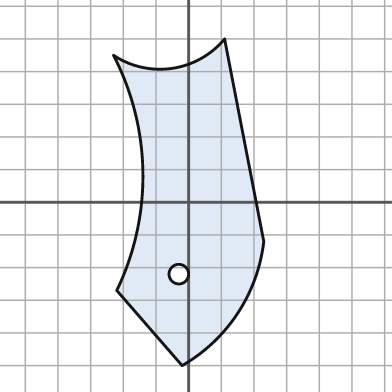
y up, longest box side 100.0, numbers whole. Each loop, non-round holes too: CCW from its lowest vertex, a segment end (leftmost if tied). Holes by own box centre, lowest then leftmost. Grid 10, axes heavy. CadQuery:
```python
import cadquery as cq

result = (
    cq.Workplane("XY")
    .moveTo(-2.0, -50.0)
    .threePointArc((15.0, -34.0), (23.0, -12.0))
    .lineTo(11.0, 50.0)
    .threePointArc((-5.0, 41.0), (-23.0, 45.0))
    .threePointArc((-14.0, 9.0), (-22.0, -27.0))
    .close()
    .moveTo(-3.0, -22.0)
    .circle(3.0)
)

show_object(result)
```